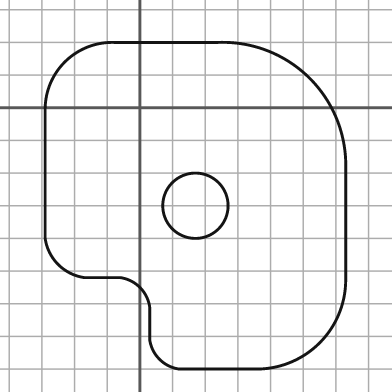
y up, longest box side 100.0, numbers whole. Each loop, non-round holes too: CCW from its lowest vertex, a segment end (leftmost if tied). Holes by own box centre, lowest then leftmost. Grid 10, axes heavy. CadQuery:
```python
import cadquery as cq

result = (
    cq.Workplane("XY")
    .moveTo(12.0, -80.0)
    .lineTo(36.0, -80.0)
    .threePointArc((55.0, -72.0), (63.0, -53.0))
    .lineTo(63.0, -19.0)
    .threePointArc((52.0, 9.0), (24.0, 20.0))
    .lineTo(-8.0, 20.0)
    .threePointArc((-23.0, 14.0), (-29.0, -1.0))
    .lineTo(-29.0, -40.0)
    .threePointArc((-25.0, -48.0), (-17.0, -52.0))
    .lineTo(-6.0, -52.0)
    .threePointArc((0.0, -55.0), (3.0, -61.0))
    .lineTo(3.0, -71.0)
    .threePointArc((6.0, -77.0), (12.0, -80.0))
    .close()
    .moveTo(17.0, -30.0)
    .circle(10.0)
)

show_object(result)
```